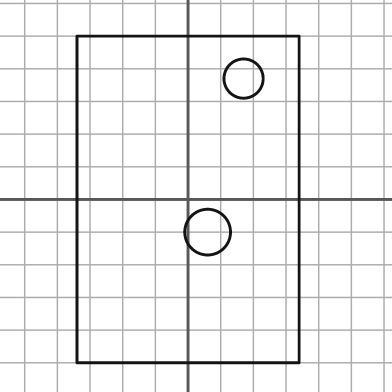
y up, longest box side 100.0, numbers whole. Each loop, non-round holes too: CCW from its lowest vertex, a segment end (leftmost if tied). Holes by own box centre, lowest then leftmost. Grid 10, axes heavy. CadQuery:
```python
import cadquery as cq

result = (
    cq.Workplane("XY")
    .moveTo(-34.0, -50.0)
    .lineTo(34.0, -50.0)
    .lineTo(34.0, 50.0)
    .lineTo(-34.0, 50.0)
    .close()
    .moveTo(6.0, -10.0)
    .circle(7.0)
    .moveTo(17.0, 37.0)
    .circle(6.0)
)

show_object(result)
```